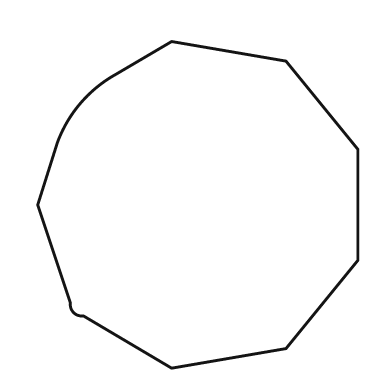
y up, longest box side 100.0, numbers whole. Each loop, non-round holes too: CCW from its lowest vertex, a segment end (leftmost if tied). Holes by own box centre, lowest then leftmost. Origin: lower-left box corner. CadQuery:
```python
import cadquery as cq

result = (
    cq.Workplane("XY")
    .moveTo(41.0, 0.0)
    .lineTo(76.0, 6.0)
    .lineTo(98.0, 33.0)
    .lineTo(98.0, 67.0)
    .lineTo(76.0, 94.0)
    .lineTo(41.0, 100.0)
    .lineTo(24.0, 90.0)
    .threePointArc((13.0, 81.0), (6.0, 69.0))
    .lineTo(0.0, 50.0)
    .lineTo(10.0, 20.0)
    .threePointArc((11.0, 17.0), (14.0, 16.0))
    .close()
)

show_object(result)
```